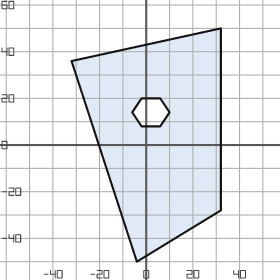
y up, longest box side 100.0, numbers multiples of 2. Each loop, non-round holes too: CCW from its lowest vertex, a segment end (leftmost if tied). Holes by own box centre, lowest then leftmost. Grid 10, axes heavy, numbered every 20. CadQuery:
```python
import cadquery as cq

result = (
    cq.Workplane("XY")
    .moveTo(-4.0, -50.0)
    .lineTo(32.0, -28.0)
    .lineTo(32.0, 50.0)
    .lineTo(-32.0, 36.0)
    .close()
    .moveTo(-2.0, 8.0)
    .lineTo(6.0, 8.0)
    .lineTo(10.0, 14.0)
    .lineTo(6.0, 20.0)
    .lineTo(-2.0, 20.0)
    .lineTo(-6.0, 14.0)
    .close()
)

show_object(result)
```